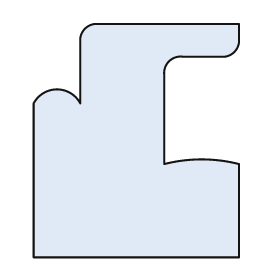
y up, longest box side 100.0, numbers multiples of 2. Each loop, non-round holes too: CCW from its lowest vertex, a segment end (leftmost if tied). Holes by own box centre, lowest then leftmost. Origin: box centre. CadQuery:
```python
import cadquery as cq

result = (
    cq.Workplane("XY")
    .moveTo(-44.0, -50.0)
    .lineTo(44.0, -50.0)
    .lineTo(44.0, -10.0)
    .threePointArc((28.0, -8.0), (12.0, -10.0))
    .lineTo(12.0, 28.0)
    .threePointArc((14.0, 34.0), (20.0, 36.0))
    .lineTo(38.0, 36.0)
    .threePointArc((42.0, 38.0), (44.0, 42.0))
    .lineTo(44.0, 50.0)
    .lineTo(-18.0, 50.0)
    .threePointArc((-22.0, 48.0), (-24.0, 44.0))
    .lineTo(-24.0, 16.0)
    .threePointArc((-34.0, 22.0), (-44.0, 16.0))
    .close()
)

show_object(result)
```